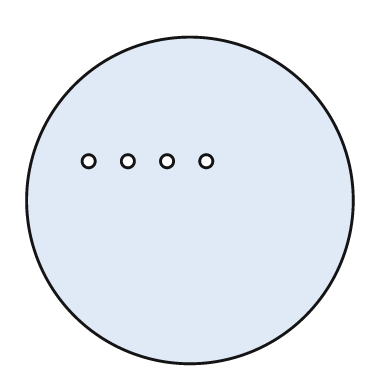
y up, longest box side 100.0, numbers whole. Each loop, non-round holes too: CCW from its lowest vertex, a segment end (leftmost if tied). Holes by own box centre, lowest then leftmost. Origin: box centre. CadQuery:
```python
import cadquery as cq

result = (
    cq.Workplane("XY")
    .moveTo(0.0, 0.0)
    .circle(50.0)
    .moveTo(-31.0, 12.0)
    .circle(2.0)
    .moveTo(-19.0, 12.0)
    .circle(2.0)
    .moveTo(-7.0, 12.0)
    .circle(2.0)
    .moveTo(5.0, 12.0)
    .circle(2.0)
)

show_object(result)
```